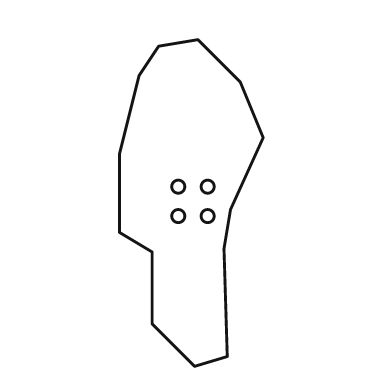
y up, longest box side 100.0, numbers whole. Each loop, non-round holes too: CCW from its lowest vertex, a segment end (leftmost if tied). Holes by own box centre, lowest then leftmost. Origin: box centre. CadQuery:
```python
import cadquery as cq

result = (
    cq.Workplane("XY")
    .moveTo(1.0, -50.0)
    .lineTo(11.0, -47.0)
    .lineTo(10.0, -14.0)
    .lineTo(12.0, -2.0)
    .lineTo(22.0, 20.0)
    .lineTo(15.0, 37.0)
    .lineTo(2.0, 50.0)
    .lineTo(-10.0, 48.0)
    .lineTo(-16.0, 39.0)
    .lineTo(-22.0, 15.0)
    .lineTo(-22.0, -9.0)
    .lineTo(-12.0, -15.0)
    .lineTo(-12.0, -37.0)
    .close()
    .moveTo(-4.0, -4.0)
    .circle(2.0)
    .moveTo(5.0, -4.0)
    .circle(2.0)
    .moveTo(-4.0, 5.0)
    .circle(2.0)
    .moveTo(5.0, 5.0)
    .circle(2.0)
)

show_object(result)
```